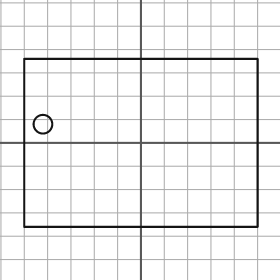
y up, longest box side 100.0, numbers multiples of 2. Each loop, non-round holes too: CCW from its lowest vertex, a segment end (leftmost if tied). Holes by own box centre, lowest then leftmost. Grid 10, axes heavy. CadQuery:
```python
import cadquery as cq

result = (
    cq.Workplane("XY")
    .moveTo(-50.0, -36.0)
    .lineTo(50.0, -36.0)
    .lineTo(50.0, 36.0)
    .lineTo(-50.0, 36.0)
    .close()
    .moveTo(-42.0, 8.0)
    .circle(4.0)
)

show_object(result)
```